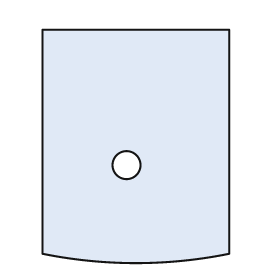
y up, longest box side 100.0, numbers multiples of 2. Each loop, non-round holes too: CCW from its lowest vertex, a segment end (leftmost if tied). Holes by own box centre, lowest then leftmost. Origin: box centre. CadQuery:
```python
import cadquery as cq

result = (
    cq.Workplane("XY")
    .moveTo(-40.0, -46.0)
    .threePointArc((0.0, -50.0), (40.0, -46.0))
    .lineTo(40.0, 50.0)
    .lineTo(-40.0, 50.0)
    .close()
    .moveTo(-4.0, -8.0)
    .circle(6.0)
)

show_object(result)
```